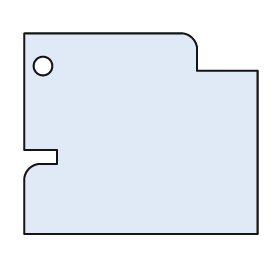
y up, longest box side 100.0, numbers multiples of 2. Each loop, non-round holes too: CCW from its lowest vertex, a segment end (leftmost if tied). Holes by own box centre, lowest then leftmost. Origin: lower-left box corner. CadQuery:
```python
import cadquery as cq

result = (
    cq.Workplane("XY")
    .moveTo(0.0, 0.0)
    .lineTo(100.0, 0.0)
    .lineTo(100.0, 70.0)
    .lineTo(74.0, 70.0)
    .lineTo(74.0, 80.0)
    .threePointArc((72.0, 84.0), (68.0, 86.0))
    .lineTo(0.0, 86.0)
    .lineTo(0.0, 36.0)
    .lineTo(14.0, 36.0)
    .lineTo(14.0, 30.0)
    .lineTo(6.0, 30.0)
    .threePointArc((2.0, 28.0), (0.0, 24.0))
    .close()
    .moveTo(8.0, 72.0)
    .circle(4.0)
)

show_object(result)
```